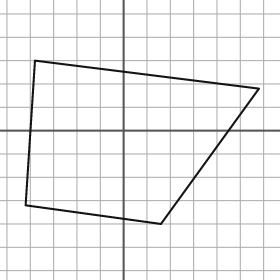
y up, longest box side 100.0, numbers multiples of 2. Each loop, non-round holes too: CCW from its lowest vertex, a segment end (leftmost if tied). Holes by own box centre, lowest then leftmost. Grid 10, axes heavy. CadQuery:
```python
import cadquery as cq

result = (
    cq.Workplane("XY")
    .moveTo(16.0, -40.0)
    .lineTo(58.0, 18.0)
    .lineTo(-38.0, 30.0)
    .lineTo(-42.0, -32.0)
    .close()
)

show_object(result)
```